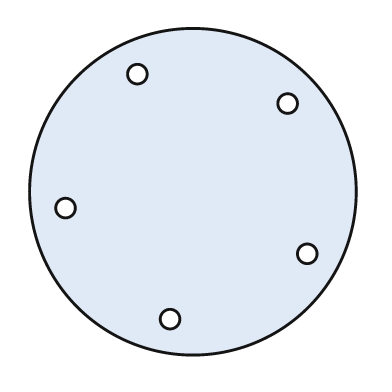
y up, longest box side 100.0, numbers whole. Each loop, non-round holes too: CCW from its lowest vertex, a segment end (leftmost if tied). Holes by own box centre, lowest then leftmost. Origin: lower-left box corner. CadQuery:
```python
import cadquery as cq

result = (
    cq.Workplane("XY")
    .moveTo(50.0, 50.0)
    .circle(50.0)
    .moveTo(43.0, 11.0)
    .circle(3.0)
    .moveTo(85.0, 31.0)
    .circle(3.0)
    .moveTo(11.0, 45.0)
    .circle(3.0)
    .moveTo(79.0, 77.0)
    .circle(3.0)
    .moveTo(33.0, 86.0)
    .circle(3.0)
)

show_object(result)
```